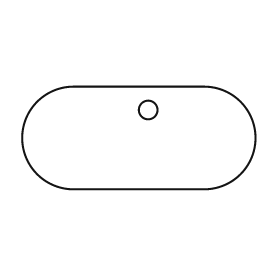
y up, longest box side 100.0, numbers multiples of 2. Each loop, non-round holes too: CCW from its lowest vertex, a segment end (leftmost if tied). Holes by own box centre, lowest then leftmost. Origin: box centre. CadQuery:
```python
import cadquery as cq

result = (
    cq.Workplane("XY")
    .moveTo(-28.0, -22.0)
    .lineTo(28.0, -22.0)
    .threePointArc((50.0, 0.0), (28.0, 22.0))
    .lineTo(-28.0, 22.0)
    .threePointArc((-50.0, 0.0), (-28.0, -22.0))
    .close()
    .moveTo(4.0, 12.0)
    .circle(4.0)
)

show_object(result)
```